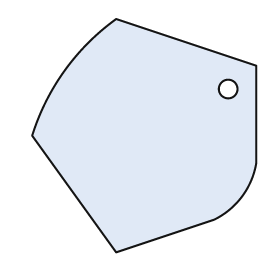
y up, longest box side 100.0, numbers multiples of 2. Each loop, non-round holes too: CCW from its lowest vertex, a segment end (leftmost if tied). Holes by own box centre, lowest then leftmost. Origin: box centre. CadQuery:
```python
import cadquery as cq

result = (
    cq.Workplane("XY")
    .moveTo(-12.0, -50.0)
    .lineTo(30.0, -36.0)
    .threePointArc((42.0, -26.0), (48.0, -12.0))
    .lineTo(48.0, 30.0)
    .lineTo(-12.0, 50.0)
    .threePointArc((-34.0, 28.0), (-48.0, 0.0))
    .close()
    .moveTo(36.0, 20.0)
    .circle(4.0)
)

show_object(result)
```